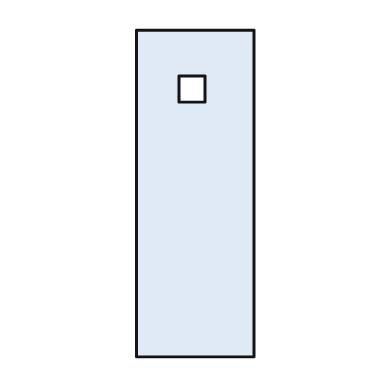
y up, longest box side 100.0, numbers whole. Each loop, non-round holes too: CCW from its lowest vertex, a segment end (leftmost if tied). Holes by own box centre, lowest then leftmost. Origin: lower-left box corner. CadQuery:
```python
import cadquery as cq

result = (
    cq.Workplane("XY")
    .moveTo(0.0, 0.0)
    .lineTo(36.0, 0.0)
    .lineTo(36.0, 100.0)
    .lineTo(0.0, 100.0)
    .close()
    .moveTo(13.0, 78.0)
    .lineTo(21.0, 78.0)
    .lineTo(21.0, 86.0)
    .lineTo(13.0, 86.0)
    .close()
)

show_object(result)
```